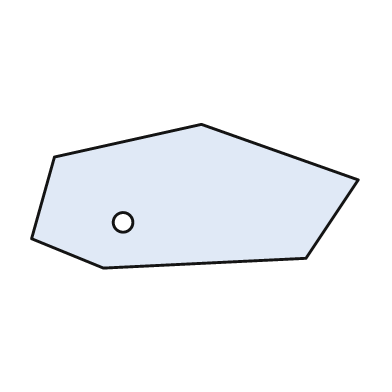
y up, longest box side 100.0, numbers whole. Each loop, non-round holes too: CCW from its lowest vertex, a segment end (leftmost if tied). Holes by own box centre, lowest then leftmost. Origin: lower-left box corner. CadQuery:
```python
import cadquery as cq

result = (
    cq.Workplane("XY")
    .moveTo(22.0, 0.0)
    .lineTo(84.0, 3.0)
    .lineTo(100.0, 27.0)
    .lineTo(52.0, 44.0)
    .lineTo(7.0, 34.0)
    .lineTo(0.0, 9.0)
    .close()
    .moveTo(28.0, 14.0)
    .circle(3.0)
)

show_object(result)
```